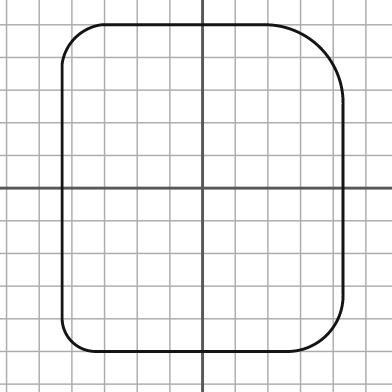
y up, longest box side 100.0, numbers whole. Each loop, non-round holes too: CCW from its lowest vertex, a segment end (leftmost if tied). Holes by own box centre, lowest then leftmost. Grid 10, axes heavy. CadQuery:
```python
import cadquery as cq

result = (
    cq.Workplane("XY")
    .moveTo(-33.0, -50.0)
    .lineTo(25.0, -50.0)
    .threePointArc((38.0, -45.0), (43.0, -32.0))
    .lineTo(43.0, 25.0)
    .threePointArc((36.0, 43.0), (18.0, 50.0))
    .lineTo(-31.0, 50.0)
    .threePointArc((-39.0, 46.0), (-43.0, 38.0))
    .lineTo(-43.0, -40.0)
    .threePointArc((-40.0, -47.0), (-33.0, -50.0))
    .close()
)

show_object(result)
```